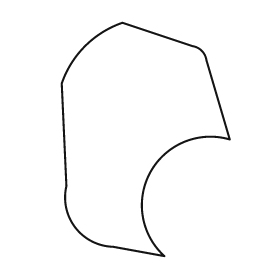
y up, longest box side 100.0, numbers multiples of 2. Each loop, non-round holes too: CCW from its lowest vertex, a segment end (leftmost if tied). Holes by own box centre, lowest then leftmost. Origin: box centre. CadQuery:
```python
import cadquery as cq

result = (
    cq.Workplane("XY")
    .moveTo(8.0, -50.0)
    .threePointArc((2.0, -14.0), (36.0, 0.0))
    .lineTo(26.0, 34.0)
    .threePointArc((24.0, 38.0), (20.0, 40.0))
    .lineTo(-10.0, 50.0)
    .threePointArc((-26.0, 40.0), (-36.0, 24.0))
    .lineTo(-34.0, -20.0)
    .threePointArc((-30.0, -38.0), (-14.0, -46.0))
    .close()
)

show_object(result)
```